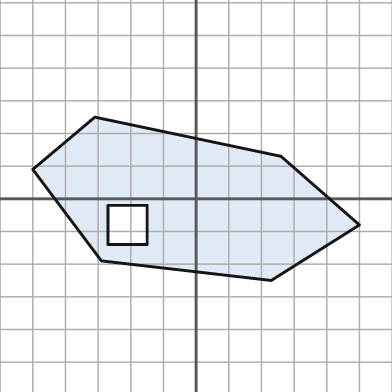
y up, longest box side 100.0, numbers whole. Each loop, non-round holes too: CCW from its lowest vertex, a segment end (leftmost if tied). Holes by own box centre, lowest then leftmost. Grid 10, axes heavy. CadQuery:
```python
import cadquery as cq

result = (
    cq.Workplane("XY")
    .moveTo(23.0, -25.0)
    .lineTo(50.0, -8.0)
    .lineTo(26.0, 13.0)
    .lineTo(-31.0, 25.0)
    .lineTo(-50.0, 9.0)
    .lineTo(-29.0, -19.0)
    .close()
    .moveTo(-27.0, -14.0)
    .lineTo(-15.0, -14.0)
    .lineTo(-15.0, -2.0)
    .lineTo(-27.0, -2.0)
    .close()
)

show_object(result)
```